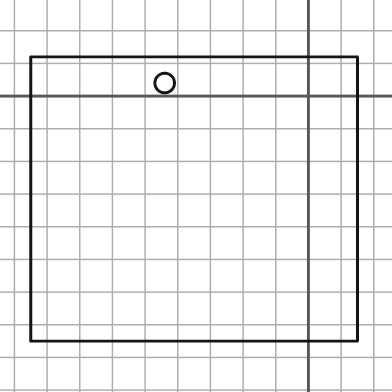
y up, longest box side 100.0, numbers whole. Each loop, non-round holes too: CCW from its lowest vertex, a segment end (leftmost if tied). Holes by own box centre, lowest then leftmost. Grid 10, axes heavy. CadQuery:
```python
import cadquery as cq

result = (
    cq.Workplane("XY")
    .moveTo(-85.0, -75.0)
    .lineTo(15.0, -75.0)
    .lineTo(15.0, 12.0)
    .lineTo(-85.0, 12.0)
    .close()
    .moveTo(-44.0, 4.0)
    .circle(3.0)
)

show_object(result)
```